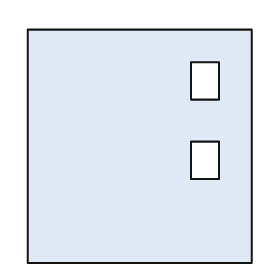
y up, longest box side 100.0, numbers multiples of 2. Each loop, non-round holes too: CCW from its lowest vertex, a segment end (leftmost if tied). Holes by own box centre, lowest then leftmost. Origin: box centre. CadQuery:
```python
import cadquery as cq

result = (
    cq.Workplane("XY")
    .moveTo(-48.0, -50.0)
    .lineTo(48.0, -50.0)
    .lineTo(48.0, 50.0)
    .lineTo(-48.0, 50.0)
    .close()
    .moveTo(22.0, -14.0)
    .lineTo(34.0, -14.0)
    .lineTo(34.0, 2.0)
    .lineTo(22.0, 2.0)
    .close()
    .moveTo(22.0, 20.0)
    .lineTo(34.0, 20.0)
    .lineTo(34.0, 36.0)
    .lineTo(22.0, 36.0)
    .close()
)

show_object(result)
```